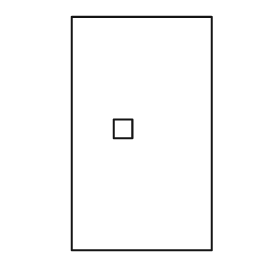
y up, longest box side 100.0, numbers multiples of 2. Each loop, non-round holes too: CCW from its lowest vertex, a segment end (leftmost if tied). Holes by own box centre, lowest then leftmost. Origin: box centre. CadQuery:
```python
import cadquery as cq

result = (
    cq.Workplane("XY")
    .moveTo(-30.0, -50.0)
    .lineTo(30.0, -50.0)
    .lineTo(30.0, 50.0)
    .lineTo(-30.0, 50.0)
    .close()
    .moveTo(-12.0, -2.0)
    .lineTo(-4.0, -2.0)
    .lineTo(-4.0, 6.0)
    .lineTo(-12.0, 6.0)
    .close()
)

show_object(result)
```